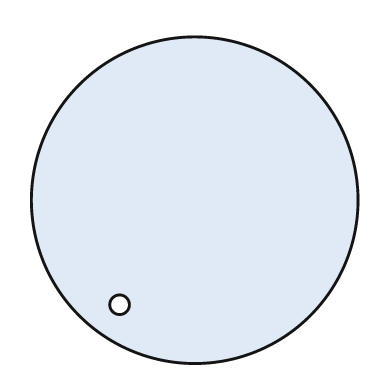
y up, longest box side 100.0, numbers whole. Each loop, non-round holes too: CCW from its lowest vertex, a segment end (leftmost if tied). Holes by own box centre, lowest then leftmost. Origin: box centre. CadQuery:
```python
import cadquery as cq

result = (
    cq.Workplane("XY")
    .moveTo(0.0, 0.0)
    .circle(50.0)
    .moveTo(-23.0, -32.0)
    .circle(3.0)
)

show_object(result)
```